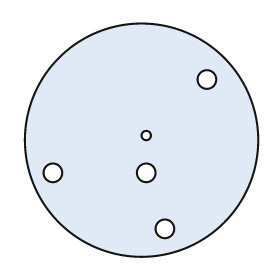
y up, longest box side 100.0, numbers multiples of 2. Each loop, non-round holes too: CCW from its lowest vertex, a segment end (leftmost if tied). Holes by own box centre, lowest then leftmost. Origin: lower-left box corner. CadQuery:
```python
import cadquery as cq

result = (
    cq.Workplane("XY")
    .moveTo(50.0, 50.0)
    .circle(50.0)
    .moveTo(60.0, 12.0)
    .circle(4.0)
    .moveTo(12.0, 36.0)
    .circle(4.0)
    .moveTo(52.0, 36.0)
    .circle(4.0)
    .moveTo(52.0, 52.0)
    .circle(2.0)
    .moveTo(78.0, 76.0)
    .circle(4.0)
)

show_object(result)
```